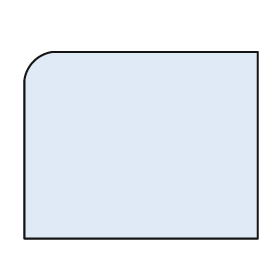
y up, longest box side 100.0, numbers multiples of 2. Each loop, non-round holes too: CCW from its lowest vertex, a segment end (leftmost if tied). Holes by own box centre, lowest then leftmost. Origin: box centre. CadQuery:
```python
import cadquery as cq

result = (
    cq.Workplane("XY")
    .moveTo(-50.0, -40.0)
    .lineTo(50.0, -40.0)
    .lineTo(50.0, 40.0)
    .lineTo(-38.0, 40.0)
    .threePointArc((-46.0, 36.0), (-50.0, 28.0))
    .close()
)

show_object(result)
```